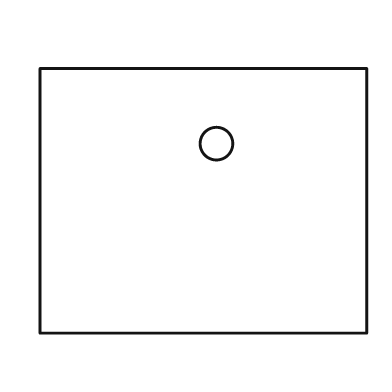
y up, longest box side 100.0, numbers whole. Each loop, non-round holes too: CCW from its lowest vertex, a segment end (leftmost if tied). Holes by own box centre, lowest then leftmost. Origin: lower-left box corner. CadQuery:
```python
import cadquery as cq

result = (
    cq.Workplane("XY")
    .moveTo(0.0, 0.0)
    .lineTo(100.0, 0.0)
    .lineTo(100.0, 81.0)
    .lineTo(0.0, 81.0)
    .close()
    .moveTo(54.0, 58.0)
    .circle(5.0)
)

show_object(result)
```